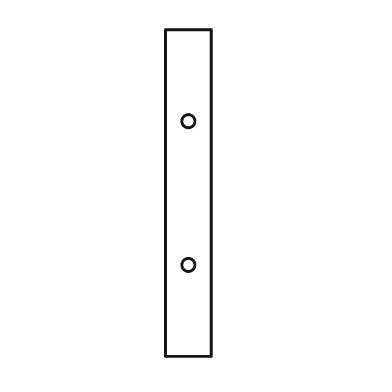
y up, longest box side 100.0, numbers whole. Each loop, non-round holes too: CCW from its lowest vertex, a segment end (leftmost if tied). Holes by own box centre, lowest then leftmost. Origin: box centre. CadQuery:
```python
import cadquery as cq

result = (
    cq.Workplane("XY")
    .moveTo(-7.0, -50.0)
    .lineTo(7.0, -50.0)
    .lineTo(7.0, 50.0)
    .lineTo(-7.0, 50.0)
    .close()
    .moveTo(0.0, -22.0)
    .circle(2.0)
    .moveTo(0.0, 22.0)
    .circle(2.0)
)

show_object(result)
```